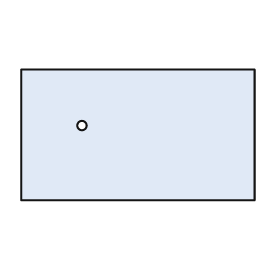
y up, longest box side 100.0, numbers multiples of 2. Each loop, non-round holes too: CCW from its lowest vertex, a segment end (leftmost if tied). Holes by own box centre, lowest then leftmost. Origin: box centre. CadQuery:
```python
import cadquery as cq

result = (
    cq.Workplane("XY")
    .moveTo(-50.0, -28.0)
    .lineTo(50.0, -28.0)
    .lineTo(50.0, 28.0)
    .lineTo(-50.0, 28.0)
    .close()
    .moveTo(-24.0, 4.0)
    .circle(2.0)
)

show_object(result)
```